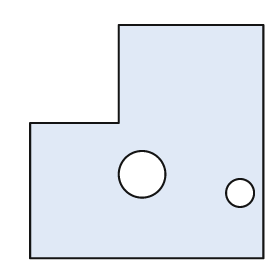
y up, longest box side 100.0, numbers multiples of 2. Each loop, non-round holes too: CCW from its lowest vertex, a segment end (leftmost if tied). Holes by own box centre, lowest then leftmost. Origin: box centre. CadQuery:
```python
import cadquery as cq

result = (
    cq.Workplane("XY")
    .moveTo(-50.0, -50.0)
    .lineTo(50.0, -50.0)
    .lineTo(50.0, 50.0)
    .lineTo(-12.0, 50.0)
    .lineTo(-12.0, 8.0)
    .lineTo(-50.0, 8.0)
    .close()
    .moveTo(40.0, -22.0)
    .circle(6.0)
    .moveTo(-2.0, -14.0)
    .circle(10.0)
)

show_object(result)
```